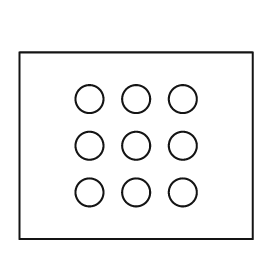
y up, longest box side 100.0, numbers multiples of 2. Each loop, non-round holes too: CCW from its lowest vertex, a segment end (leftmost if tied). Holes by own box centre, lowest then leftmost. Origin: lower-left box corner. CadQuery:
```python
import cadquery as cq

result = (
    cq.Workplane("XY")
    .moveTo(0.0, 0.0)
    .lineTo(100.0, 0.0)
    .lineTo(100.0, 80.0)
    .lineTo(0.0, 80.0)
    .close()
    .moveTo(30.0, 20.0)
    .circle(6.0)
    .moveTo(50.0, 20.0)
    .circle(6.0)
    .moveTo(70.0, 20.0)
    .circle(6.0)
    .moveTo(30.0, 40.0)
    .circle(6.0)
    .moveTo(50.0, 40.0)
    .circle(6.0)
    .moveTo(70.0, 40.0)
    .circle(6.0)
    .moveTo(30.0, 60.0)
    .circle(6.0)
    .moveTo(50.0, 60.0)
    .circle(6.0)
    .moveTo(70.0, 60.0)
    .circle(6.0)
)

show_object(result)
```